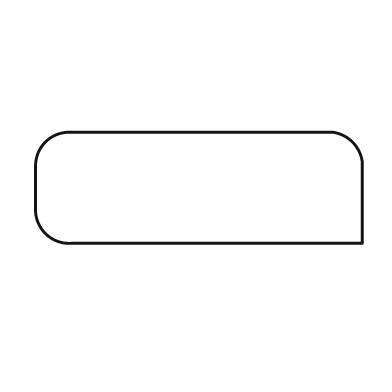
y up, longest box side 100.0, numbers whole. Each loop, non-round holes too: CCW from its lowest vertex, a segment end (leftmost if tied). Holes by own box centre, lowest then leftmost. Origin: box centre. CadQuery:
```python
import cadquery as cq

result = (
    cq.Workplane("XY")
    .moveTo(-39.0, -17.0)
    .lineTo(50.0, -17.0)
    .lineTo(50.0, 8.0)
    .threePointArc((47.0, 14.0), (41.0, 17.0))
    .lineTo(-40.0, 17.0)
    .threePointArc((-47.0, 14.0), (-50.0, 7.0))
    .lineTo(-50.0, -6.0)
    .threePointArc((-47.0, -14.0), (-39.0, -17.0))
    .close()
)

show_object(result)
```